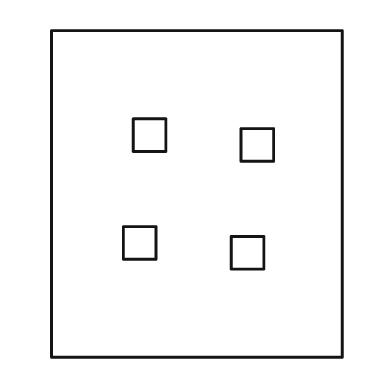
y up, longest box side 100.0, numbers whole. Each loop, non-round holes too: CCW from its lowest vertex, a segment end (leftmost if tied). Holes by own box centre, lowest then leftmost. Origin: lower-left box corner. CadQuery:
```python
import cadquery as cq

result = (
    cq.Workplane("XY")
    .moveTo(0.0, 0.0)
    .lineTo(89.0, 0.0)
    .lineTo(89.0, 100.0)
    .lineTo(0.0, 100.0)
    .close()
    .moveTo(55.0, 27.0)
    .lineTo(65.0, 27.0)
    .lineTo(65.0, 37.0)
    .lineTo(55.0, 37.0)
    .close()
    .moveTo(22.0, 30.0)
    .lineTo(32.0, 30.0)
    .lineTo(32.0, 40.0)
    .lineTo(22.0, 40.0)
    .close()
    .moveTo(58.0, 60.0)
    .lineTo(68.0, 60.0)
    .lineTo(68.0, 70.0)
    .lineTo(58.0, 70.0)
    .close()
    .moveTo(25.0, 63.0)
    .lineTo(35.0, 63.0)
    .lineTo(35.0, 73.0)
    .lineTo(25.0, 73.0)
    .close()
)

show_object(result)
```